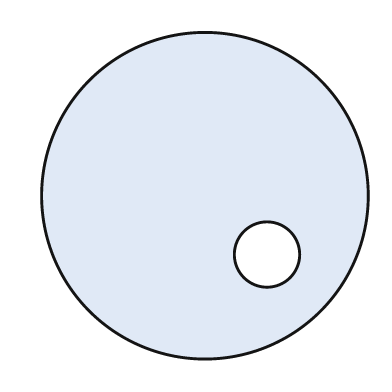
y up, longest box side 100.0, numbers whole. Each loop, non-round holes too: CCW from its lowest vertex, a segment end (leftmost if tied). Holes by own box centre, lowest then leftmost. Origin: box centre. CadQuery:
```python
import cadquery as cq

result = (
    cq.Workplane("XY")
    .moveTo(0.0, 0.0)
    .circle(50.0)
    .moveTo(19.0, -18.0)
    .circle(10.0)
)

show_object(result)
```